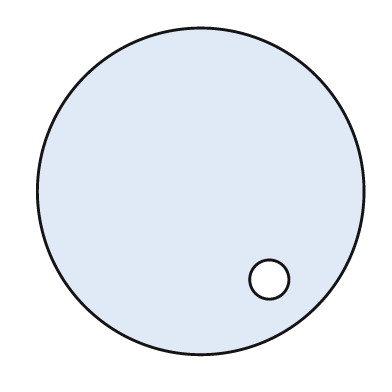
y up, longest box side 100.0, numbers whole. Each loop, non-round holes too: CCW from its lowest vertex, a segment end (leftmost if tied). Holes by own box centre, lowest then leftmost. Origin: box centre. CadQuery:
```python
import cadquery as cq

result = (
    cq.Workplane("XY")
    .moveTo(0.0, 0.0)
    .circle(50.0)
    .moveTo(21.0, -27.0)
    .circle(6.0)
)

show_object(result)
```